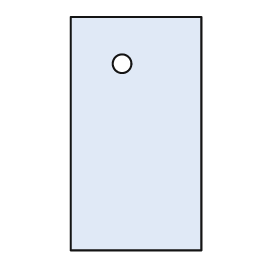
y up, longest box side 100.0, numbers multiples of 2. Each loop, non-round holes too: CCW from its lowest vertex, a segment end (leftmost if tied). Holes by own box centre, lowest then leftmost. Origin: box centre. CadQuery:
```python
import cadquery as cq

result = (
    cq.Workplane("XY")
    .moveTo(-28.0, -50.0)
    .lineTo(28.0, -50.0)
    .lineTo(28.0, 50.0)
    .lineTo(-28.0, 50.0)
    .close()
    .moveTo(-6.0, 30.0)
    .circle(4.0)
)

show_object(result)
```